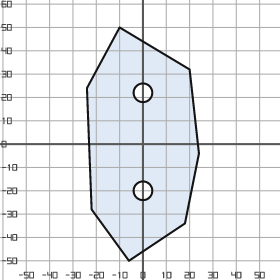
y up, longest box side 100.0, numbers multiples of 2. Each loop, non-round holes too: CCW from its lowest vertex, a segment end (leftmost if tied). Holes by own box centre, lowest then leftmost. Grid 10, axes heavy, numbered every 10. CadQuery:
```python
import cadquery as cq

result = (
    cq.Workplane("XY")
    .moveTo(-6.0, -50.0)
    .lineTo(18.0, -34.0)
    .lineTo(24.0, -4.0)
    .lineTo(20.0, 32.0)
    .lineTo(-10.0, 50.0)
    .lineTo(-24.0, 24.0)
    .lineTo(-22.0, -28.0)
    .close()
    .moveTo(0.0, -20.0)
    .circle(4.0)
    .moveTo(0.0, 22.0)
    .circle(4.0)
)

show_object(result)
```